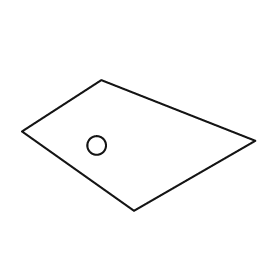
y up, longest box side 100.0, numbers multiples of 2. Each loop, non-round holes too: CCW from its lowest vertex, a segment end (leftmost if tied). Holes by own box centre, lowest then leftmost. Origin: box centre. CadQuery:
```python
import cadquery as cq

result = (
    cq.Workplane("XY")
    .moveTo(-2.0, -28.0)
    .lineTo(50.0, 2.0)
    .lineTo(-16.0, 28.0)
    .lineTo(-50.0, 6.0)
    .close()
    .moveTo(-18.0, 0.0)
    .circle(4.0)
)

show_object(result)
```